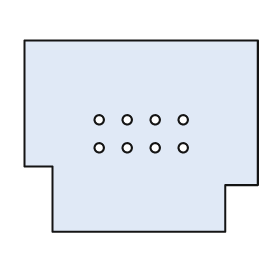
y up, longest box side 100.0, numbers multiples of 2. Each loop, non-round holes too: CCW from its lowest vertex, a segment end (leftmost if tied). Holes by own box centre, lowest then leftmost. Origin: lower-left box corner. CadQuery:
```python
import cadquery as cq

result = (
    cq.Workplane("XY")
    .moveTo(12.0, 0.0)
    .lineTo(86.0, 0.0)
    .lineTo(86.0, 20.0)
    .lineTo(100.0, 20.0)
    .lineTo(100.0, 82.0)
    .lineTo(0.0, 82.0)
    .lineTo(0.0, 28.0)
    .lineTo(12.0, 28.0)
    .close()
    .moveTo(32.0, 36.0)
    .circle(2.0)
    .moveTo(44.0, 36.0)
    .circle(2.0)
    .moveTo(56.0, 36.0)
    .circle(2.0)
    .moveTo(68.0, 36.0)
    .circle(2.0)
    .moveTo(32.0, 48.0)
    .circle(2.0)
    .moveTo(44.0, 48.0)
    .circle(2.0)
    .moveTo(56.0, 48.0)
    .circle(2.0)
    .moveTo(68.0, 48.0)
    .circle(2.0)
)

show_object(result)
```